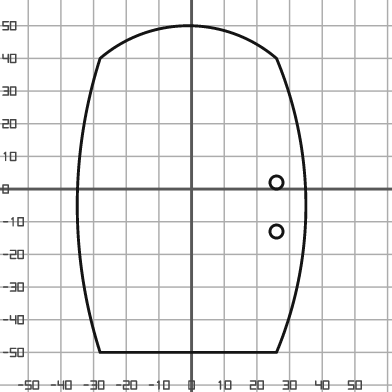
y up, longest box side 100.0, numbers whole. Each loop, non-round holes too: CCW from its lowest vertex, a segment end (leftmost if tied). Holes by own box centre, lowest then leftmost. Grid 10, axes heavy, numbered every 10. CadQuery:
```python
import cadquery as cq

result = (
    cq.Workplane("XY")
    .moveTo(-28.0, -50.0)
    .lineTo(26.0, -50.0)
    .threePointArc((35.0, -5.0), (26.0, 40.0))
    .threePointArc((-1.0, 50.0), (-28.0, 40.0))
    .threePointArc((-35.0, -5.0), (-28.0, -50.0))
    .close()
    .moveTo(26.0, -13.0)
    .circle(2.0)
    .moveTo(26.0, 2.0)
    .circle(2.0)
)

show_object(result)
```